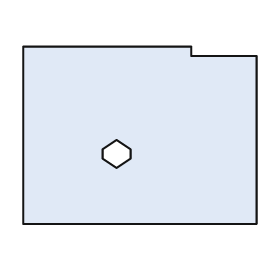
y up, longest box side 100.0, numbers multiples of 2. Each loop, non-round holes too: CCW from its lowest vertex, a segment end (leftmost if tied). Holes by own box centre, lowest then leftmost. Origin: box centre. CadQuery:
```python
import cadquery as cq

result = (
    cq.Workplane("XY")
    .moveTo(-50.0, -38.0)
    .lineTo(50.0, -38.0)
    .lineTo(50.0, 34.0)
    .lineTo(22.0, 34.0)
    .lineTo(22.0, 38.0)
    .lineTo(-50.0, 38.0)
    .close()
    .moveTo(-10.0, -14.0)
    .lineTo(-4.0, -10.0)
    .lineTo(-4.0, -6.0)
    .lineTo(-10.0, -2.0)
    .lineTo(-16.0, -6.0)
    .lineTo(-16.0, -10.0)
    .close()
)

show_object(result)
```